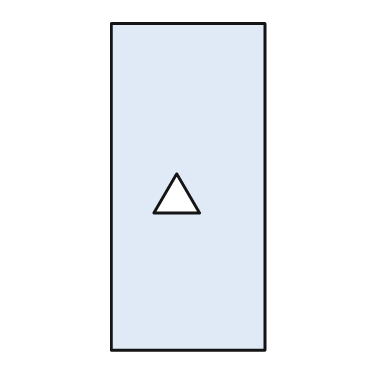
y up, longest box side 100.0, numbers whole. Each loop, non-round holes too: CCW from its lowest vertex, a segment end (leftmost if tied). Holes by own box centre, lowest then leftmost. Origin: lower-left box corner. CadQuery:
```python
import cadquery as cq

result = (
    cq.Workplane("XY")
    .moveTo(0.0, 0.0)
    .lineTo(47.0, 0.0)
    .lineTo(47.0, 100.0)
    .lineTo(0.0, 100.0)
    .close()
    .moveTo(13.0, 42.0)
    .lineTo(27.0, 42.0)
    .lineTo(20.0, 54.0)
    .close()
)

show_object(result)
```